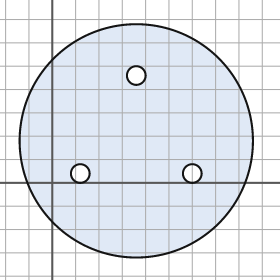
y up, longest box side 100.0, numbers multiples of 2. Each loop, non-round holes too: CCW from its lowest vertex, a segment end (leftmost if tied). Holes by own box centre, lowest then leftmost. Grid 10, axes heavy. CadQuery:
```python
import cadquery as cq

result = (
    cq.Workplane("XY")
    .moveTo(36.0, 18.0)
    .circle(50.0)
    .moveTo(12.0, 4.0)
    .circle(4.0)
    .moveTo(60.0, 4.0)
    .circle(4.0)
    .moveTo(36.0, 46.0)
    .circle(4.0)
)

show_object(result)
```